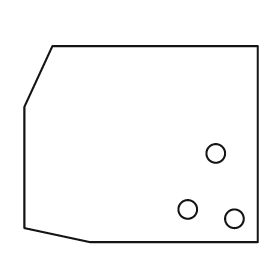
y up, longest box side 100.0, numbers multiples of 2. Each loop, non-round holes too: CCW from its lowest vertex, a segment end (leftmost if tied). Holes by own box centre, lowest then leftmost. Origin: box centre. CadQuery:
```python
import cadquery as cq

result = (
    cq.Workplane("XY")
    .moveTo(-22.0, -42.0)
    .lineTo(50.0, -42.0)
    .lineTo(50.0, 42.0)
    .lineTo(-38.0, 42.0)
    .lineTo(-50.0, 16.0)
    .lineTo(-50.0, -36.0)
    .close()
    .moveTo(40.0, -32.0)
    .circle(4.0)
    .moveTo(20.0, -28.0)
    .circle(4.0)
    .moveTo(32.0, -4.0)
    .circle(4.0)
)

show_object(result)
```